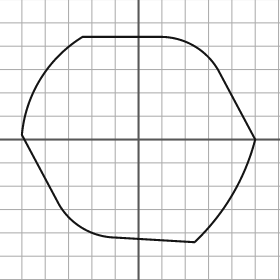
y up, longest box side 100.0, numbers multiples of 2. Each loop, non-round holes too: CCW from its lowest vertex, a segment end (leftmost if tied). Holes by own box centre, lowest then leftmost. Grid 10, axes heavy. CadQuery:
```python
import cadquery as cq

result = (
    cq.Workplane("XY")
    .moveTo(24.0, -44.0)
    .threePointArc((40.0, -24.0), (50.0, 0.0))
    .lineTo(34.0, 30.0)
    .threePointArc((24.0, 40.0), (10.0, 44.0))
    .lineTo(-24.0, 44.0)
    .threePointArc((-42.0, 26.0), (-50.0, 2.0))
    .lineTo(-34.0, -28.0)
    .threePointArc((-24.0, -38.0), (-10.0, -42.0))
    .close()
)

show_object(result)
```